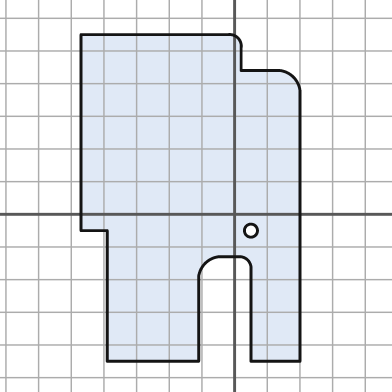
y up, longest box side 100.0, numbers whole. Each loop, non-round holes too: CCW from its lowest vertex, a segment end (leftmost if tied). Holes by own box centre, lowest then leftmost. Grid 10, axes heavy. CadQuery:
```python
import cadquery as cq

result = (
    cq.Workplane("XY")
    .moveTo(-39.0, -45.0)
    .lineTo(-11.0, -45.0)
    .lineTo(-11.0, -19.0)
    .threePointArc((-9.0, -15.0), (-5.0, -13.0))
    .lineTo(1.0, -13.0)
    .threePointArc((4.0, -14.0), (5.0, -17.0))
    .lineTo(5.0, -45.0)
    .lineTo(20.0, -45.0)
    .lineTo(20.0, 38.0)
    .threePointArc((18.0, 42.0), (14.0, 44.0))
    .lineTo(2.0, 44.0)
    .lineTo(2.0, 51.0)
    .threePointArc((1.0, 54.0), (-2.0, 55.0))
    .lineTo(-47.0, 55.0)
    .lineTo(-47.0, -5.0)
    .lineTo(-39.0, -5.0)
    .close()
    .moveTo(5.0, -5.0)
    .circle(2.0)
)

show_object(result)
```